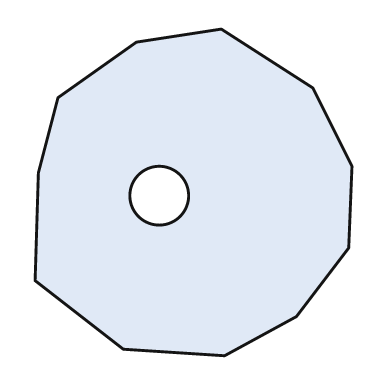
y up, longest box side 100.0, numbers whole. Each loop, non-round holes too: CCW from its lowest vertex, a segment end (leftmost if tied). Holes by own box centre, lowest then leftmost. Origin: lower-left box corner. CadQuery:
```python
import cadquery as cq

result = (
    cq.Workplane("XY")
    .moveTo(58.0, 0.0)
    .lineTo(80.0, 12.0)
    .lineTo(96.0, 33.0)
    .lineTo(97.0, 58.0)
    .lineTo(85.0, 82.0)
    .lineTo(57.0, 100.0)
    .lineTo(31.0, 96.0)
    .lineTo(7.0, 79.0)
    .lineTo(1.0, 56.0)
    .lineTo(0.0, 23.0)
    .lineTo(27.0, 2.0)
    .close()
    .moveTo(38.0, 49.0)
    .circle(9.0)
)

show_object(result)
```